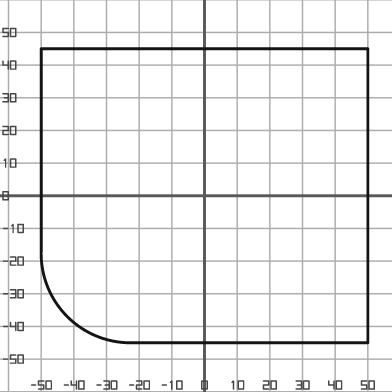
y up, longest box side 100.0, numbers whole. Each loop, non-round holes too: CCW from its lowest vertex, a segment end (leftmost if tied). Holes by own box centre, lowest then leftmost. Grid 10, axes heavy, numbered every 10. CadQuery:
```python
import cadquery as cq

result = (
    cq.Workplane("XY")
    .moveTo(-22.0, -45.0)
    .lineTo(50.0, -45.0)
    .lineTo(50.0, 45.0)
    .lineTo(-50.0, 45.0)
    .lineTo(-50.0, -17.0)
    .threePointArc((-42.0, -37.0), (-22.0, -45.0))
    .close()
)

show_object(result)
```